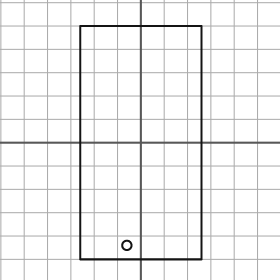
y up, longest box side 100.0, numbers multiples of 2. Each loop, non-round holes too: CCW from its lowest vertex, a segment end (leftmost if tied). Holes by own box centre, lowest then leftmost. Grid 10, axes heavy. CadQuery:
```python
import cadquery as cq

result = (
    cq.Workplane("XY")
    .moveTo(-26.0, -50.0)
    .lineTo(26.0, -50.0)
    .lineTo(26.0, 50.0)
    .lineTo(-26.0, 50.0)
    .close()
    .moveTo(-6.0, -44.0)
    .circle(2.0)
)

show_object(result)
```